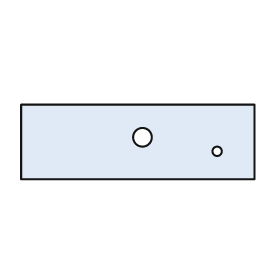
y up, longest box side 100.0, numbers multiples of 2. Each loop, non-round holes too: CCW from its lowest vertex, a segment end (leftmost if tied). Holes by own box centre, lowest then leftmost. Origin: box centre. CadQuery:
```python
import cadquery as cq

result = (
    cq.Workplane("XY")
    .moveTo(-50.0, -16.0)
    .lineTo(50.0, -16.0)
    .lineTo(50.0, 16.0)
    .lineTo(-50.0, 16.0)
    .close()
    .moveTo(34.0, -4.0)
    .circle(2.0)
    .moveTo(2.0, 2.0)
    .circle(4.0)
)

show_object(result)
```